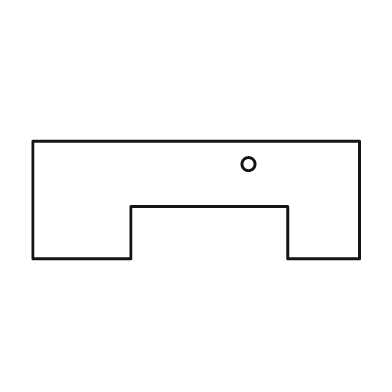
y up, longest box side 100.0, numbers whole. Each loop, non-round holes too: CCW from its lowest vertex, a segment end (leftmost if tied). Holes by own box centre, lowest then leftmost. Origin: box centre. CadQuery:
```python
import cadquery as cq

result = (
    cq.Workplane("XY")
    .moveTo(-50.0, -18.0)
    .lineTo(-20.0, -18.0)
    .lineTo(-20.0, -2.0)
    .lineTo(28.0, -2.0)
    .lineTo(28.0, -18.0)
    .lineTo(50.0, -18.0)
    .lineTo(50.0, 18.0)
    .lineTo(-50.0, 18.0)
    .close()
    .moveTo(16.0, 11.0)
    .circle(2.0)
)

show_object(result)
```